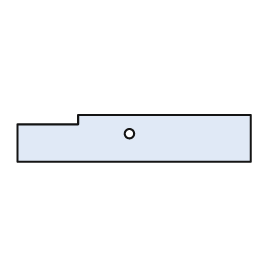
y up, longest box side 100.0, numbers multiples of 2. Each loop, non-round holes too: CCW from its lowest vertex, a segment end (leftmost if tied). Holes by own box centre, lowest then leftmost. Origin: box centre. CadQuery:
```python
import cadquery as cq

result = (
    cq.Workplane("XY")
    .moveTo(-50.0, -10.0)
    .lineTo(50.0, -10.0)
    .lineTo(50.0, 10.0)
    .lineTo(-24.0, 10.0)
    .lineTo(-24.0, 6.0)
    .lineTo(-50.0, 6.0)
    .close()
    .moveTo(-2.0, 2.0)
    .circle(2.0)
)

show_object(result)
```